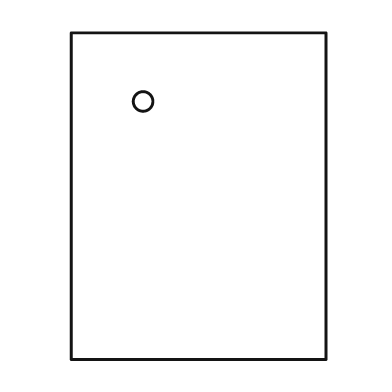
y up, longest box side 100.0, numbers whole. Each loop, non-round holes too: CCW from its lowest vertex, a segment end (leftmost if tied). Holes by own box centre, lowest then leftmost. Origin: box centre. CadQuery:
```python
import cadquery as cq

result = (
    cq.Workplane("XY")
    .moveTo(-39.0, -50.0)
    .lineTo(39.0, -50.0)
    .lineTo(39.0, 50.0)
    .lineTo(-39.0, 50.0)
    .close()
    .moveTo(-17.0, 29.0)
    .circle(3.0)
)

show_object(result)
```